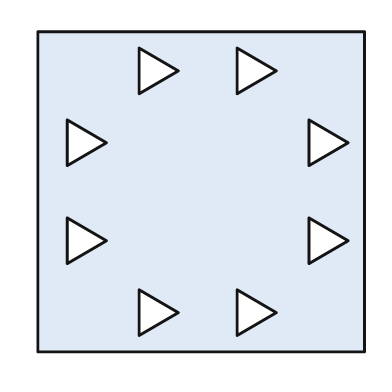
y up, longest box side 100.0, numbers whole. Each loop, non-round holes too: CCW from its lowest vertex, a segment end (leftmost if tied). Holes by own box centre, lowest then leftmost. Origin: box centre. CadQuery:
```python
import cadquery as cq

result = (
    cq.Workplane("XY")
    .moveTo(-50.0, -49.0)
    .lineTo(50.0, -49.0)
    .lineTo(50.0, 49.0)
    .lineTo(-50.0, 49.0)
    .close()
    .moveTo(-19.0, -44.0)
    .lineTo(-7.0, -37.0)
    .lineTo(-19.0, -30.0)
    .close()
    .moveTo(11.0, -44.0)
    .lineTo(23.0, -37.0)
    .lineTo(11.0, -30.0)
    .close()
    .moveTo(-41.0, -22.0)
    .lineTo(-29.0, -15.0)
    .lineTo(-41.0, -8.0)
    .close()
    .moveTo(33.0, -22.0)
    .lineTo(45.0, -15.0)
    .lineTo(33.0, -8.0)
    .close()
    .moveTo(-41.0, 8.0)
    .lineTo(-29.0, 15.0)
    .lineTo(-41.0, 22.0)
    .close()
    .moveTo(33.0, 8.0)
    .lineTo(45.0, 15.0)
    .lineTo(33.0, 22.0)
    .close()
    .moveTo(-19.0, 30.0)
    .lineTo(-7.0, 37.0)
    .lineTo(-19.0, 44.0)
    .close()
    .moveTo(11.0, 30.0)
    .lineTo(23.0, 37.0)
    .lineTo(11.0, 44.0)
    .close()
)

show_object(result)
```